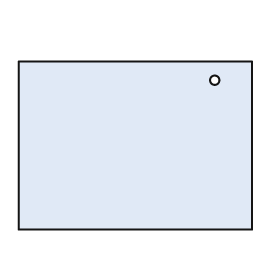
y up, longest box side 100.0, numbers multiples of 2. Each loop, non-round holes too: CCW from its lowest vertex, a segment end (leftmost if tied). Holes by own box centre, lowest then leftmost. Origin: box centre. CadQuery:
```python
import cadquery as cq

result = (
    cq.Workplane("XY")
    .moveTo(-50.0, -36.0)
    .lineTo(50.0, -36.0)
    .lineTo(50.0, 36.0)
    .lineTo(-50.0, 36.0)
    .close()
    .moveTo(34.0, 28.0)
    .circle(2.0)
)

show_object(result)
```